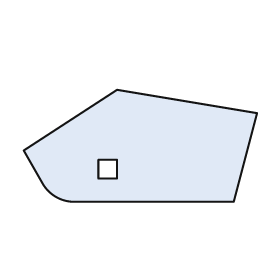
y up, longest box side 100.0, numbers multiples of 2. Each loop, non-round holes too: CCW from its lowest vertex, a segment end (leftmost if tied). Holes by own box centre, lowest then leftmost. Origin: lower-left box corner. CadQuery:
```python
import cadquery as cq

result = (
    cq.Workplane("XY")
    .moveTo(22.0, 0.0)
    .lineTo(90.0, 0.0)
    .lineTo(100.0, 38.0)
    .lineTo(40.0, 48.0)
    .lineTo(0.0, 22.0)
    .lineTo(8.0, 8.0)
    .threePointArc((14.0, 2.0), (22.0, 0.0))
    .close()
    .moveTo(32.0, 10.0)
    .lineTo(40.0, 10.0)
    .lineTo(40.0, 18.0)
    .lineTo(32.0, 18.0)
    .close()
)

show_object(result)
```